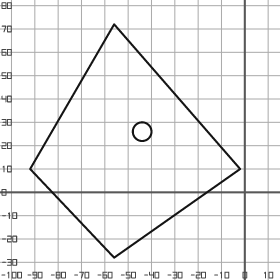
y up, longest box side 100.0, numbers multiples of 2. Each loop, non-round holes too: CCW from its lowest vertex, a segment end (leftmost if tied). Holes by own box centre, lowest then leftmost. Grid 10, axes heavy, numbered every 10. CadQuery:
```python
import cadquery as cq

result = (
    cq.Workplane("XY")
    .moveTo(-56.0, -28.0)
    .lineTo(-2.0, 10.0)
    .lineTo(-56.0, 72.0)
    .lineTo(-92.0, 10.0)
    .close()
    .moveTo(-44.0, 26.0)
    .circle(4.0)
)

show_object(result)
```